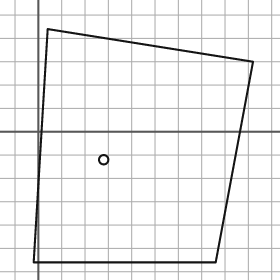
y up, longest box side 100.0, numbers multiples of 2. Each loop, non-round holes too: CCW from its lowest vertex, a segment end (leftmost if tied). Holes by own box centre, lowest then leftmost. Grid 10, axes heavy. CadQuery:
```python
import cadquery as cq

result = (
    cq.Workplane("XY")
    .moveTo(-2.0, -56.0)
    .lineTo(76.0, -56.0)
    .lineTo(92.0, 30.0)
    .lineTo(4.0, 44.0)
    .close()
    .moveTo(28.0, -12.0)
    .circle(2.0)
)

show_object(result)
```